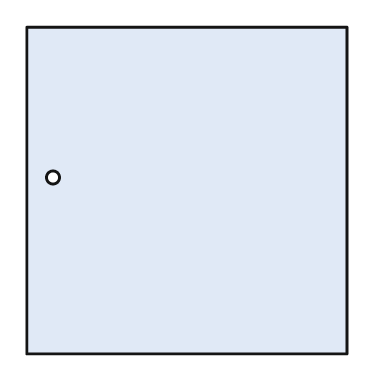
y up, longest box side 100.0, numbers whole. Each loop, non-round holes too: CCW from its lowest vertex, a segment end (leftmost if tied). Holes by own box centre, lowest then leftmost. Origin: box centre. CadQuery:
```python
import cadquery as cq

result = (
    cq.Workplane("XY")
    .moveTo(-49.0, -50.0)
    .lineTo(49.0, -50.0)
    .lineTo(49.0, 50.0)
    .lineTo(-49.0, 50.0)
    .close()
    .moveTo(-41.0, 4.0)
    .circle(2.0)
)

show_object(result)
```